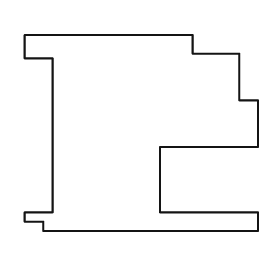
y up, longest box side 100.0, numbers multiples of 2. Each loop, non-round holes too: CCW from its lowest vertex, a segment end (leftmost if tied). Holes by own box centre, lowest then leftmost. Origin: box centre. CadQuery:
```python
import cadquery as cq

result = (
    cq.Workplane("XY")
    .moveTo(-42.0, -42.0)
    .lineTo(50.0, -42.0)
    .lineTo(50.0, -34.0)
    .lineTo(8.0, -34.0)
    .lineTo(8.0, -6.0)
    .lineTo(50.0, -6.0)
    .lineTo(50.0, 14.0)
    .lineTo(42.0, 14.0)
    .lineTo(42.0, 34.0)
    .lineTo(22.0, 34.0)
    .lineTo(22.0, 42.0)
    .lineTo(-50.0, 42.0)
    .lineTo(-50.0, 32.0)
    .lineTo(-38.0, 32.0)
    .lineTo(-38.0, -34.0)
    .lineTo(-50.0, -34.0)
    .lineTo(-50.0, -38.0)
    .lineTo(-42.0, -38.0)
    .close()
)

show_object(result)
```